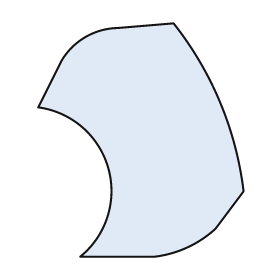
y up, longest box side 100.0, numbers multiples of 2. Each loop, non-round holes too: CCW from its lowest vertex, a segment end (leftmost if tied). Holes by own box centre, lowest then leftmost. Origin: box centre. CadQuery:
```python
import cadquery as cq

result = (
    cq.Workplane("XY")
    .moveTo(-26.0, -50.0)
    .lineTo(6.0, -50.0)
    .threePointArc((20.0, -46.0), (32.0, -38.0))
    .lineTo(44.0, -22.0)
    .threePointArc((34.0, 16.0), (14.0, 50.0))
    .lineTo(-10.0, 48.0)
    .threePointArc((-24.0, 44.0), (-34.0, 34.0))
    .lineTo(-44.0, 14.0)
    .threePointArc((-14.0, -12.0), (-26.0, -50.0))
    .close()
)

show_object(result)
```